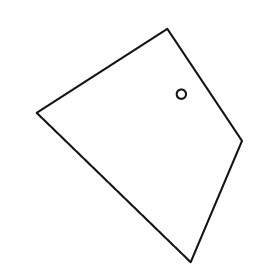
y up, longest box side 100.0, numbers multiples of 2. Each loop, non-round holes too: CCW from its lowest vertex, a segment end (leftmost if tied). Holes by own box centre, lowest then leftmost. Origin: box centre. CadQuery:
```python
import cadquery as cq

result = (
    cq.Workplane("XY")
    .moveTo(22.0, -50.0)
    .lineTo(44.0, 2.0)
    .lineTo(12.0, 50.0)
    .lineTo(-44.0, 14.0)
    .close()
    .moveTo(18.0, 22.0)
    .circle(2.0)
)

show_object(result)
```